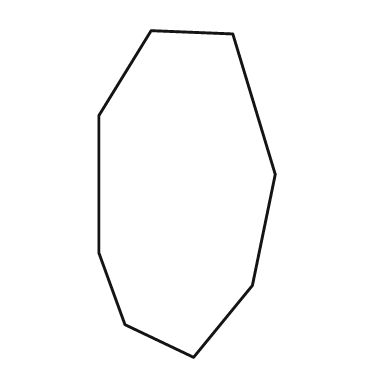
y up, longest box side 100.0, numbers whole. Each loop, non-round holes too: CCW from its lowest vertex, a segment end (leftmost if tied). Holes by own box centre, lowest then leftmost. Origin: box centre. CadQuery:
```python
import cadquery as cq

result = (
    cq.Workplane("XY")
    .moveTo(2.0, -50.0)
    .lineTo(20.0, -28.0)
    .lineTo(27.0, 6.0)
    .lineTo(14.0, 49.0)
    .lineTo(-11.0, 50.0)
    .lineTo(-27.0, 24.0)
    .lineTo(-27.0, -18.0)
    .lineTo(-19.0, -40.0)
    .close()
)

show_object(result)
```